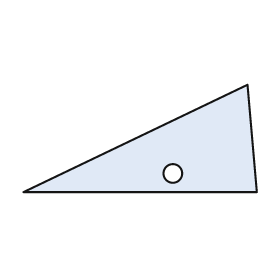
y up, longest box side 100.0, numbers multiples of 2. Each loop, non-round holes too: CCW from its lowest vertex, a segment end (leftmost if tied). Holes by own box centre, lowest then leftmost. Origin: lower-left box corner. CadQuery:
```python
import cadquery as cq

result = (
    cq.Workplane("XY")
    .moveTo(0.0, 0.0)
    .lineTo(100.0, 0.0)
    .lineTo(96.0, 46.0)
    .close()
    .moveTo(64.0, 8.0)
    .circle(4.0)
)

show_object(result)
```